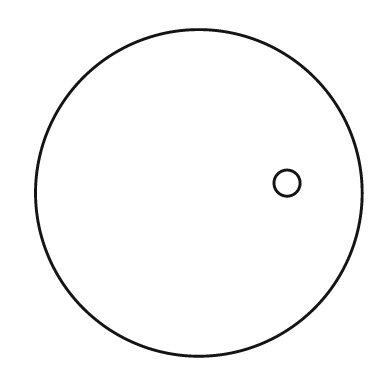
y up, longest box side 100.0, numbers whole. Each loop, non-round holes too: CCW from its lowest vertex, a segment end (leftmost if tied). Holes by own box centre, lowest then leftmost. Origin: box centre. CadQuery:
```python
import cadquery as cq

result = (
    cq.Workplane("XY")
    .moveTo(0.0, 0.0)
    .circle(50.0)
    .moveTo(27.0, 3.0)
    .circle(4.0)
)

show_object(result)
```